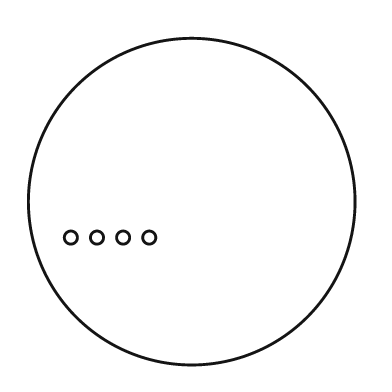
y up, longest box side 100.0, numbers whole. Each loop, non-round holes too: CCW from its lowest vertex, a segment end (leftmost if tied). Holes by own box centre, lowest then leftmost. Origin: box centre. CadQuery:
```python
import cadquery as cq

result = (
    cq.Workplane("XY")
    .moveTo(0.0, 0.0)
    .circle(50.0)
    .moveTo(-37.0, -11.0)
    .circle(2.0)
    .moveTo(-29.0, -11.0)
    .circle(2.0)
    .moveTo(-21.0, -11.0)
    .circle(2.0)
    .moveTo(-13.0, -11.0)
    .circle(2.0)
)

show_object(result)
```